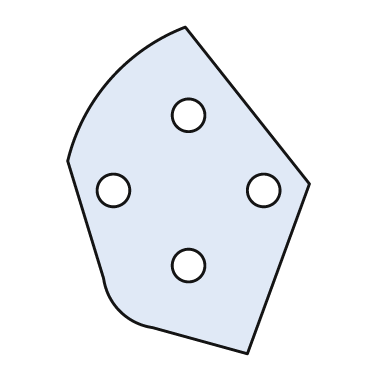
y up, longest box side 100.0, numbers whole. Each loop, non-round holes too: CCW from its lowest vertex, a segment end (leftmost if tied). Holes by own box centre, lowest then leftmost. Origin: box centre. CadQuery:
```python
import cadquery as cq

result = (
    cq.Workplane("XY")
    .moveTo(18.0, -50.0)
    .lineTo(37.0, 2.0)
    .lineTo(-1.0, 50.0)
    .threePointArc((-24.0, 34.0), (-37.0, 9.0))
    .lineTo(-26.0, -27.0)
    .threePointArc((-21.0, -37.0), (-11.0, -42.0))
    .close()
    .moveTo(0.0, -23.0)
    .circle(5.0)
    .moveTo(-23.0, 0.0)
    .circle(5.0)
    .moveTo(23.0, 0.0)
    .circle(5.0)
    .moveTo(0.0, 23.0)
    .circle(5.0)
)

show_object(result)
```